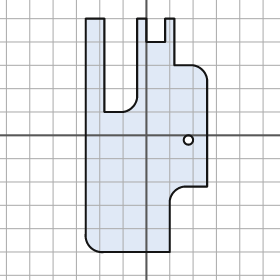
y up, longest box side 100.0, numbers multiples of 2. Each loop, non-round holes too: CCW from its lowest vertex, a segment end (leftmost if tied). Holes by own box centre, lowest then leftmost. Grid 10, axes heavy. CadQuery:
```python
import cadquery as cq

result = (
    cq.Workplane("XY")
    .moveTo(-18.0, -50.0)
    .lineTo(10.0, -50.0)
    .lineTo(10.0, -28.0)
    .threePointArc((12.0, -24.0), (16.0, -22.0))
    .lineTo(26.0, -22.0)
    .lineTo(26.0, 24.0)
    .threePointArc((24.0, 28.0), (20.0, 30.0))
    .lineTo(12.0, 30.0)
    .lineTo(12.0, 50.0)
    .lineTo(8.0, 50.0)
    .lineTo(8.0, 40.0)
    .lineTo(0.0, 40.0)
    .lineTo(0.0, 50.0)
    .lineTo(-4.0, 50.0)
    .lineTo(-4.0, 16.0)
    .threePointArc((-6.0, 12.0), (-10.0, 10.0))
    .lineTo(-18.0, 10.0)
    .lineTo(-18.0, 50.0)
    .lineTo(-26.0, 50.0)
    .lineTo(-26.0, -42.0)
    .threePointArc((-24.0, -48.0), (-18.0, -50.0))
    .close()
    .moveTo(18.0, -2.0)
    .circle(2.0)
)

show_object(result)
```